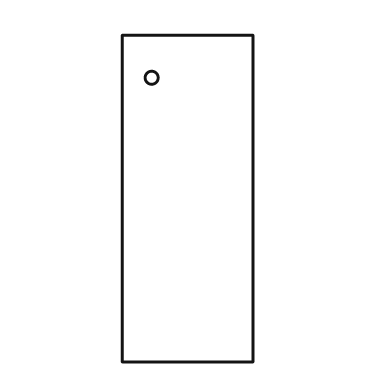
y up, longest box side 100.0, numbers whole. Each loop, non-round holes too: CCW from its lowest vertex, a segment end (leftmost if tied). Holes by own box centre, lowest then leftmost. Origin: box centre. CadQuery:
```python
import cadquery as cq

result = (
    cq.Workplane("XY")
    .moveTo(-20.0, -50.0)
    .lineTo(20.0, -50.0)
    .lineTo(20.0, 50.0)
    .lineTo(-20.0, 50.0)
    .close()
    .moveTo(-11.0, 37.0)
    .circle(2.0)
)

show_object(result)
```